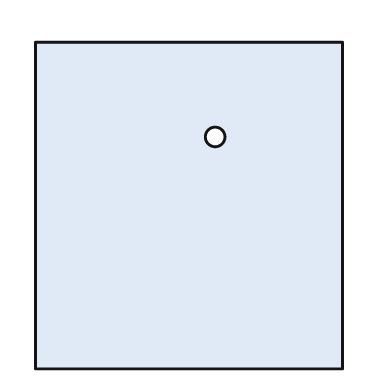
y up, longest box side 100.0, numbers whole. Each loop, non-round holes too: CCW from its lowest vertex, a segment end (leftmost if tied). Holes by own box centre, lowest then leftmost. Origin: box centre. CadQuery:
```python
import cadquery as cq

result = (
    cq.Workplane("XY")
    .moveTo(-47.0, -50.0)
    .lineTo(47.0, -50.0)
    .lineTo(47.0, 50.0)
    .lineTo(-47.0, 50.0)
    .close()
    .moveTo(8.0, 21.0)
    .circle(3.0)
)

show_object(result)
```